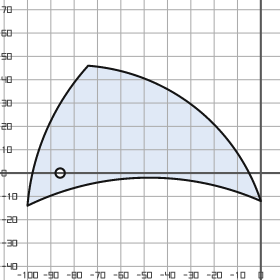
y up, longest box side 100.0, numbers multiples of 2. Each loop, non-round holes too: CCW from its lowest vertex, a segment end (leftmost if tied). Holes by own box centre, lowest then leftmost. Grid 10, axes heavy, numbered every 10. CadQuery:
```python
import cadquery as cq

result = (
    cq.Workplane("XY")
    .moveTo(-100.0, -14.0)
    .threePointArc((-50.0, -2.0), (0.0, -12.0))
    .threePointArc((-28.0, 28.0), (-74.0, 46.0))
    .threePointArc((-92.0, 18.0), (-100.0, -14.0))
    .close()
    .moveTo(-86.0, 0.0)
    .circle(2.0)
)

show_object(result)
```